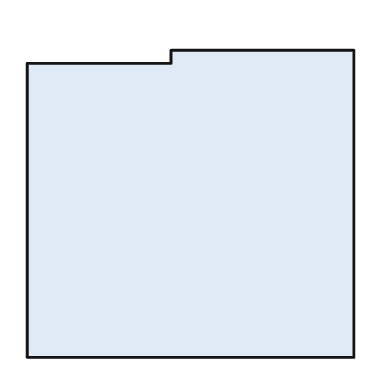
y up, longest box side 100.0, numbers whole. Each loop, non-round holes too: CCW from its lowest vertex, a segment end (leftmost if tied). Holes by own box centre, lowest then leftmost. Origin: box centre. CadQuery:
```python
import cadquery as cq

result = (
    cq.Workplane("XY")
    .moveTo(-50.0, -47.0)
    .lineTo(50.0, -47.0)
    .lineTo(50.0, 47.0)
    .lineTo(-6.0, 47.0)
    .lineTo(-6.0, 43.0)
    .lineTo(-50.0, 43.0)
    .close()
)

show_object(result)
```